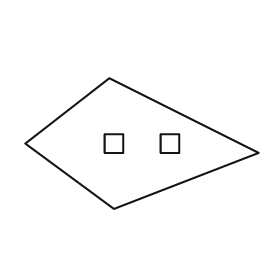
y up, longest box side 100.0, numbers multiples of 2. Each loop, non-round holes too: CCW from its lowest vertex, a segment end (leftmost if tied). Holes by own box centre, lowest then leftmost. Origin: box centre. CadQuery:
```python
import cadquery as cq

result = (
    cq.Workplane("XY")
    .moveTo(-12.0, -28.0)
    .lineTo(50.0, -4.0)
    .lineTo(-14.0, 28.0)
    .lineTo(-50.0, 0.0)
    .close()
    .moveTo(-16.0, -4.0)
    .lineTo(-8.0, -4.0)
    .lineTo(-8.0, 4.0)
    .lineTo(-16.0, 4.0)
    .close()
    .moveTo(8.0, -4.0)
    .lineTo(16.0, -4.0)
    .lineTo(16.0, 4.0)
    .lineTo(8.0, 4.0)
    .close()
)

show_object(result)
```